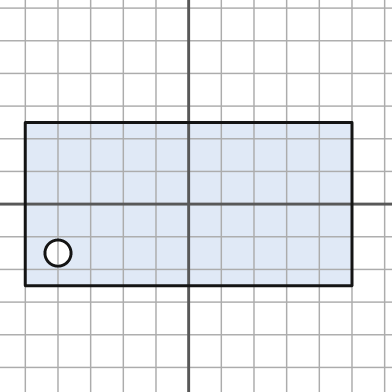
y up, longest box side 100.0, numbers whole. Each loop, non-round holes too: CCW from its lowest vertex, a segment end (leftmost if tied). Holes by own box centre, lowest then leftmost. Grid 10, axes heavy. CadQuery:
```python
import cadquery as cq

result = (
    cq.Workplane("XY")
    .moveTo(-50.0, -25.0)
    .lineTo(50.0, -25.0)
    .lineTo(50.0, 25.0)
    .lineTo(-50.0, 25.0)
    .close()
    .moveTo(-40.0, -15.0)
    .circle(4.0)
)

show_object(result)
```